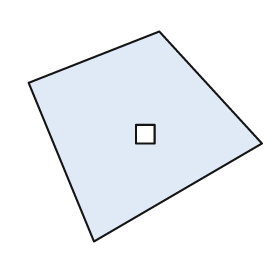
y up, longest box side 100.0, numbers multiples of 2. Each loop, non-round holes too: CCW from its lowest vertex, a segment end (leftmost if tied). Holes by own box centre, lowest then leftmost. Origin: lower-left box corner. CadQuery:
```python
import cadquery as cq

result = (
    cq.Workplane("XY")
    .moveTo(28.0, 0.0)
    .lineTo(100.0, 42.0)
    .lineTo(56.0, 90.0)
    .lineTo(0.0, 68.0)
    .close()
    .moveTo(46.0, 42.0)
    .lineTo(54.0, 42.0)
    .lineTo(54.0, 50.0)
    .lineTo(46.0, 50.0)
    .close()
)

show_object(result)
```